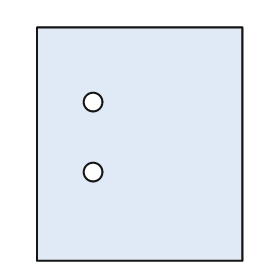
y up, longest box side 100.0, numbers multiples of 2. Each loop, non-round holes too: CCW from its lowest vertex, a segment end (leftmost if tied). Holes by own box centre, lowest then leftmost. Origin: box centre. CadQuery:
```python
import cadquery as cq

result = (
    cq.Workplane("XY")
    .moveTo(-44.0, -50.0)
    .lineTo(44.0, -50.0)
    .lineTo(44.0, 50.0)
    .lineTo(-44.0, 50.0)
    .close()
    .moveTo(-20.0, -12.0)
    .circle(4.0)
    .moveTo(-20.0, 18.0)
    .circle(4.0)
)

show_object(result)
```